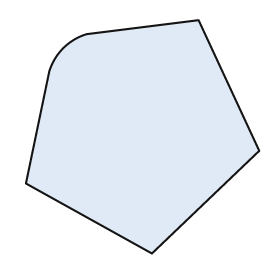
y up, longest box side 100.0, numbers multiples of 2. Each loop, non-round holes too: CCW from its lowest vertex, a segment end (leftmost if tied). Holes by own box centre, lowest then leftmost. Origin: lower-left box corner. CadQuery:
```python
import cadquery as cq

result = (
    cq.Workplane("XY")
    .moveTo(54.0, 0.0)
    .lineTo(100.0, 44.0)
    .lineTo(74.0, 100.0)
    .lineTo(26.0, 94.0)
    .threePointArc((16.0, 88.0), (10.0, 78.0))
    .lineTo(0.0, 30.0)
    .close()
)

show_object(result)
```